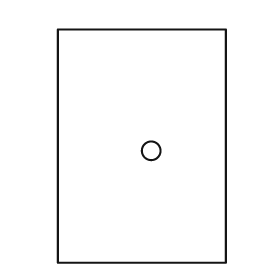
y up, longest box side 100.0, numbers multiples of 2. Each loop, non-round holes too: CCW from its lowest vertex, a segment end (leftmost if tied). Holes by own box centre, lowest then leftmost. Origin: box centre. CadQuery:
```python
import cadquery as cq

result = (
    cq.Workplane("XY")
    .moveTo(-36.0, -50.0)
    .lineTo(36.0, -50.0)
    .lineTo(36.0, 50.0)
    .lineTo(-36.0, 50.0)
    .close()
    .moveTo(4.0, -2.0)
    .circle(4.0)
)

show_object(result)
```